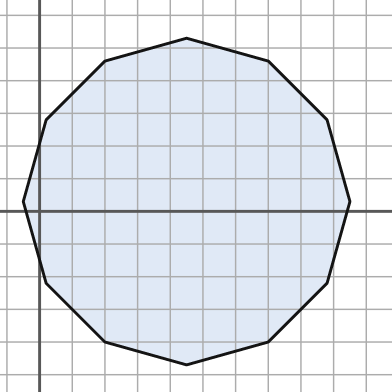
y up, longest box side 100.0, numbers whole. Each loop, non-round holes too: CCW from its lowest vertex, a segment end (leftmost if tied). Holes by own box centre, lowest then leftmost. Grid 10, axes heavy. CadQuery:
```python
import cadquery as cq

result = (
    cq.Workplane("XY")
    .moveTo(45.0, -47.0)
    .lineTo(70.0, -40.0)
    .lineTo(88.0, -22.0)
    .lineTo(95.0, 3.0)
    .lineTo(88.0, 28.0)
    .lineTo(70.0, 46.0)
    .lineTo(45.0, 53.0)
    .lineTo(20.0, 46.0)
    .lineTo(2.0, 28.0)
    .lineTo(-5.0, 3.0)
    .lineTo(2.0, -22.0)
    .lineTo(20.0, -40.0)
    .close()
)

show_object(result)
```